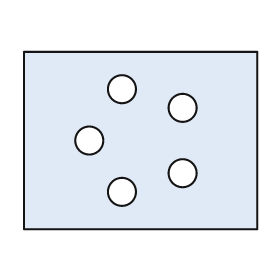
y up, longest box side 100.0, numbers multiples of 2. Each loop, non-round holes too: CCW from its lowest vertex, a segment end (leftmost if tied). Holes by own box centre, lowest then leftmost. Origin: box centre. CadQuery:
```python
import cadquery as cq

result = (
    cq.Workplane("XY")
    .moveTo(-50.0, -38.0)
    .lineTo(50.0, -38.0)
    .lineTo(50.0, 38.0)
    .lineTo(-50.0, 38.0)
    .close()
    .moveTo(-8.0, -22.0)
    .circle(6.0)
    .moveTo(18.0, -14.0)
    .circle(6.0)
    .moveTo(-22.0, 0.0)
    .circle(6.0)
    .moveTo(18.0, 14.0)
    .circle(6.0)
    .moveTo(-8.0, 22.0)
    .circle(6.0)
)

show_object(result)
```